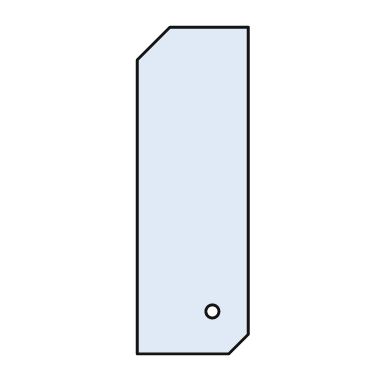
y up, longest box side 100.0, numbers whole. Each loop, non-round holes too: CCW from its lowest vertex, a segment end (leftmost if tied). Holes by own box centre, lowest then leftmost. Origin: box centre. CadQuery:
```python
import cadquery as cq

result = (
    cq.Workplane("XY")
    .moveTo(-17.0, -50.0)
    .lineTo(11.0, -50.0)
    .lineTo(17.0, -44.0)
    .lineTo(17.0, 50.0)
    .lineTo(-7.0, 50.0)
    .lineTo(-17.0, 40.0)
    .close()
    .moveTo(6.0, -37.0)
    .circle(2.0)
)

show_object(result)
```